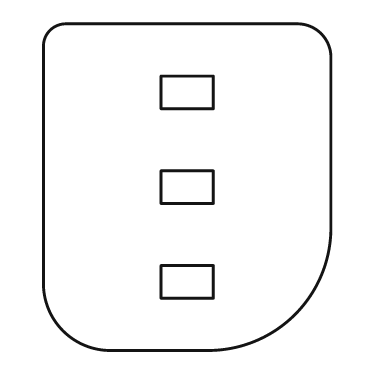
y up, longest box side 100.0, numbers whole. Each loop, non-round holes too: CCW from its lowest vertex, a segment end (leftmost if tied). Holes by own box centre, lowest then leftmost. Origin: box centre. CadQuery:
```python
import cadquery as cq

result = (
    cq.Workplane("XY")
    .moveTo(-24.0, -50.0)
    .lineTo(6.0, -50.0)
    .threePointArc((33.0, -39.0), (44.0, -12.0))
    .lineTo(44.0, 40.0)
    .threePointArc((41.0, 47.0), (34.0, 50.0))
    .lineTo(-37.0, 50.0)
    .threePointArc((-42.0, 48.0), (-44.0, 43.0))
    .lineTo(-44.0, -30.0)
    .threePointArc((-38.0, -44.0), (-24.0, -50.0))
    .close()
    .moveTo(-8.0, -34.0)
    .lineTo(8.0, -34.0)
    .lineTo(8.0, -24.0)
    .lineTo(-8.0, -24.0)
    .close()
    .moveTo(-8.0, -5.0)
    .lineTo(8.0, -5.0)
    .lineTo(8.0, 5.0)
    .lineTo(-8.0, 5.0)
    .close()
    .moveTo(-8.0, 24.0)
    .lineTo(8.0, 24.0)
    .lineTo(8.0, 34.0)
    .lineTo(-8.0, 34.0)
    .close()
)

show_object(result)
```